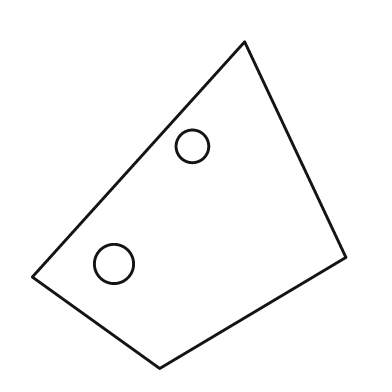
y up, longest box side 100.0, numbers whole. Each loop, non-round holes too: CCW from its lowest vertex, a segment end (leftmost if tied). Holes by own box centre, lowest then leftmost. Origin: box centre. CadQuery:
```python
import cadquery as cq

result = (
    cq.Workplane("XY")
    .moveTo(-9.0, -50.0)
    .lineTo(48.0, -16.0)
    .lineTo(17.0, 50.0)
    .lineTo(-48.0, -22.0)
    .close()
    .moveTo(-23.0, -18.0)
    .circle(6.0)
    .moveTo(1.0, 18.0)
    .circle(5.0)
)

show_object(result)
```